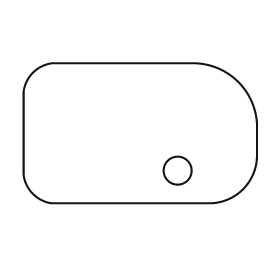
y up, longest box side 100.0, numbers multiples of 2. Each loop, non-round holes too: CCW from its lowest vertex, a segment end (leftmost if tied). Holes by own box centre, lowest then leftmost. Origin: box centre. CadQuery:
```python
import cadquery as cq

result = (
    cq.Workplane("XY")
    .moveTo(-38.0, -30.0)
    .lineTo(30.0, -30.0)
    .threePointArc((44.0, -24.0), (50.0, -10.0))
    .lineTo(50.0, 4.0)
    .threePointArc((42.0, 22.0), (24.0, 30.0))
    .lineTo(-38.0, 30.0)
    .threePointArc((-46.0, 26.0), (-50.0, 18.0))
    .lineTo(-50.0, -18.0)
    .threePointArc((-46.0, -26.0), (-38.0, -30.0))
    .close()
    .moveTo(16.0, -16.0)
    .circle(6.0)
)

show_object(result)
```